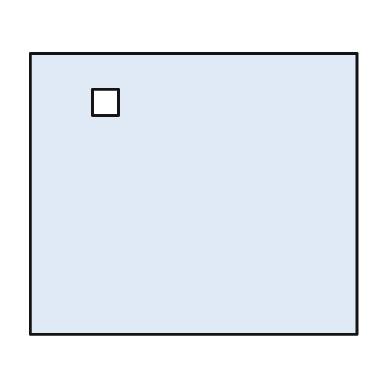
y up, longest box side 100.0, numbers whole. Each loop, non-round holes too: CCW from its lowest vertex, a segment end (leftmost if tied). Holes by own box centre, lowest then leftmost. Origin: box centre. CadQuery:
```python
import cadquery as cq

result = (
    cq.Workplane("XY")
    .moveTo(-50.0, -43.0)
    .lineTo(50.0, -43.0)
    .lineTo(50.0, 43.0)
    .lineTo(-50.0, 43.0)
    .close()
    .moveTo(-31.0, 24.0)
    .lineTo(-23.0, 24.0)
    .lineTo(-23.0, 32.0)
    .lineTo(-31.0, 32.0)
    .close()
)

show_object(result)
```